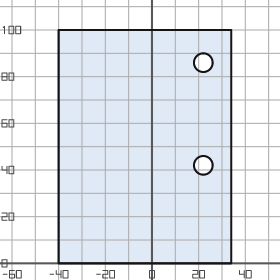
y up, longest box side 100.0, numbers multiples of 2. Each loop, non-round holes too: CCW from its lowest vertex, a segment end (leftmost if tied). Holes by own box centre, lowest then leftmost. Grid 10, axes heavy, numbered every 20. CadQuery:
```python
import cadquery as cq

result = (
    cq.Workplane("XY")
    .moveTo(-40.0, 0.0)
    .lineTo(34.0, 0.0)
    .lineTo(34.0, 100.0)
    .lineTo(-40.0, 100.0)
    .close()
    .moveTo(22.0, 42.0)
    .circle(4.0)
    .moveTo(22.0, 86.0)
    .circle(4.0)
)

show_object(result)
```